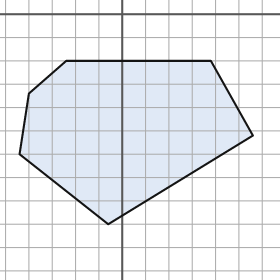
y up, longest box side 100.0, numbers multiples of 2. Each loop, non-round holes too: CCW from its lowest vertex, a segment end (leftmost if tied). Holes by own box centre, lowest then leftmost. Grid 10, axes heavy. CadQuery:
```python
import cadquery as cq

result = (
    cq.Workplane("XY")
    .moveTo(-6.0, -90.0)
    .lineTo(56.0, -52.0)
    .lineTo(38.0, -20.0)
    .lineTo(-24.0, -20.0)
    .lineTo(-40.0, -34.0)
    .lineTo(-44.0, -60.0)
    .close()
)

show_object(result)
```